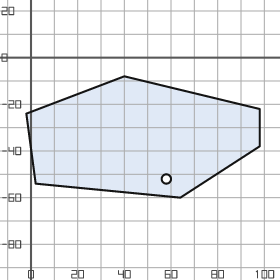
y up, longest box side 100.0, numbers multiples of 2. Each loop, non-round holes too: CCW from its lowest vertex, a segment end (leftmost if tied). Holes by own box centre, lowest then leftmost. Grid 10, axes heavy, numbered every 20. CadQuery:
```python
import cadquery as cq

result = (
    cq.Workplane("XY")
    .moveTo(64.0, -60.0)
    .lineTo(98.0, -38.0)
    .lineTo(98.0, -22.0)
    .lineTo(40.0, -8.0)
    .lineTo(-2.0, -24.0)
    .lineTo(2.0, -54.0)
    .close()
    .moveTo(58.0, -52.0)
    .circle(2.0)
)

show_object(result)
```